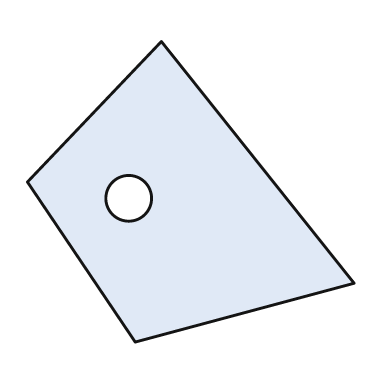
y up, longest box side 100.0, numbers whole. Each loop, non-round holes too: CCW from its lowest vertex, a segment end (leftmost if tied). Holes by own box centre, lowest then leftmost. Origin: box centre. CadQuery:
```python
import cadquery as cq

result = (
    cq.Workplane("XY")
    .moveTo(-17.0, -46.0)
    .lineTo(50.0, -28.0)
    .lineTo(-9.0, 46.0)
    .lineTo(-50.0, 3.0)
    .close()
    .moveTo(-19.0, -2.0)
    .circle(7.0)
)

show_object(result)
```